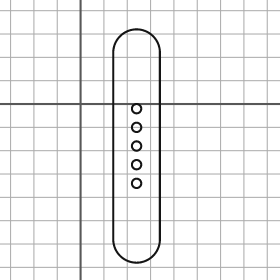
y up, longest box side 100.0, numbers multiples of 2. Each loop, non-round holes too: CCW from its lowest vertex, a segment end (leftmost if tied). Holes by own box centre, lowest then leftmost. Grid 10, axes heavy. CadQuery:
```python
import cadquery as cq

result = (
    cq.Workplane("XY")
    .moveTo(14.0, -58.0)
    .threePointArc((24.0, -68.0), (34.0, -58.0))
    .lineTo(34.0, 22.0)
    .threePointArc((24.0, 32.0), (14.0, 22.0))
    .close()
    .moveTo(24.0, -34.0)
    .circle(2.0)
    .moveTo(24.0, -26.0)
    .circle(2.0)
    .moveTo(24.0, -18.0)
    .circle(2.0)
    .moveTo(24.0, -10.0)
    .circle(2.0)
    .moveTo(24.0, -2.0)
    .circle(2.0)
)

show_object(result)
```